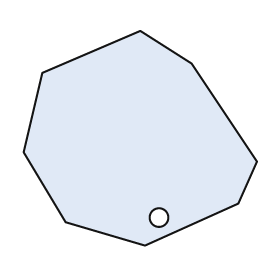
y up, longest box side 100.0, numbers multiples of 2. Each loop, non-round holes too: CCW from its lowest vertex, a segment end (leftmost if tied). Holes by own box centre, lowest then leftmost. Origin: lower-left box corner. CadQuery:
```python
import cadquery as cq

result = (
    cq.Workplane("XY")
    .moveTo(52.0, 0.0)
    .lineTo(92.0, 18.0)
    .lineTo(100.0, 36.0)
    .lineTo(72.0, 78.0)
    .lineTo(50.0, 92.0)
    .lineTo(8.0, 74.0)
    .lineTo(0.0, 40.0)
    .lineTo(18.0, 10.0)
    .close()
    .moveTo(58.0, 12.0)
    .circle(4.0)
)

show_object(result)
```